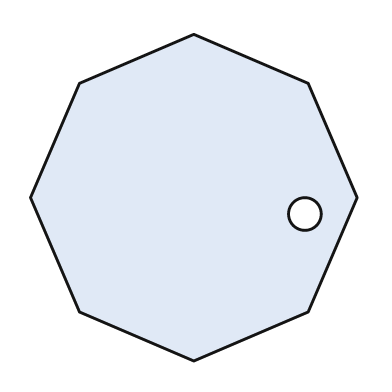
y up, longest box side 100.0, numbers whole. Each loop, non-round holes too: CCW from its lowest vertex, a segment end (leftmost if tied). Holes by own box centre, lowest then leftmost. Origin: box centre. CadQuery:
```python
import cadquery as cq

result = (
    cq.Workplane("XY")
    .moveTo(0.0, -50.0)
    .lineTo(35.0, -35.0)
    .lineTo(50.0, 0.0)
    .lineTo(35.0, 35.0)
    .lineTo(0.0, 50.0)
    .lineTo(-35.0, 35.0)
    .lineTo(-50.0, 0.0)
    .lineTo(-35.0, -35.0)
    .close()
    .moveTo(34.0, -5.0)
    .circle(5.0)
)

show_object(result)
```